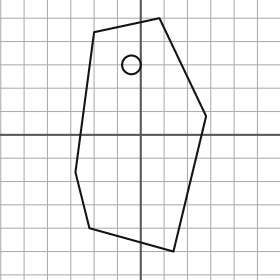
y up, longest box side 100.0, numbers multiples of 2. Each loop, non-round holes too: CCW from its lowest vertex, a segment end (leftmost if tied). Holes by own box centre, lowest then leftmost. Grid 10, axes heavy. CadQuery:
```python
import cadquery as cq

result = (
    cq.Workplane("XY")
    .moveTo(14.0, -50.0)
    .lineTo(28.0, 8.0)
    .lineTo(8.0, 50.0)
    .lineTo(-20.0, 44.0)
    .lineTo(-28.0, -16.0)
    .lineTo(-22.0, -40.0)
    .close()
    .moveTo(-4.0, 30.0)
    .circle(4.0)
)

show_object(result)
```